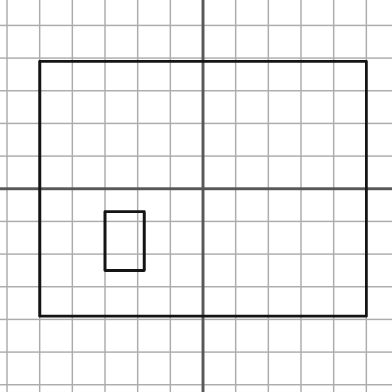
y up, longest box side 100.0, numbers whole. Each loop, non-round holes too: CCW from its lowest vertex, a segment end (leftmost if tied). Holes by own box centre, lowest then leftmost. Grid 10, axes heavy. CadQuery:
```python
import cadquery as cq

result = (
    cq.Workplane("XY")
    .moveTo(-50.0, -39.0)
    .lineTo(50.0, -39.0)
    .lineTo(50.0, 39.0)
    .lineTo(-50.0, 39.0)
    .close()
    .moveTo(-30.0, -25.0)
    .lineTo(-18.0, -25.0)
    .lineTo(-18.0, -7.0)
    .lineTo(-30.0, -7.0)
    .close()
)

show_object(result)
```